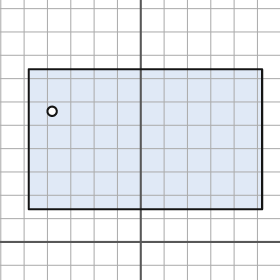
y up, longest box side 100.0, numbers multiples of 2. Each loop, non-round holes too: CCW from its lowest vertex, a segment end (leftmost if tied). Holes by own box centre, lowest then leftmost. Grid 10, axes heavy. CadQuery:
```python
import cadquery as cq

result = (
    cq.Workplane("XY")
    .moveTo(-48.0, 14.0)
    .lineTo(52.0, 14.0)
    .lineTo(52.0, 74.0)
    .lineTo(-48.0, 74.0)
    .close()
    .moveTo(-38.0, 56.0)
    .circle(2.0)
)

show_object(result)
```